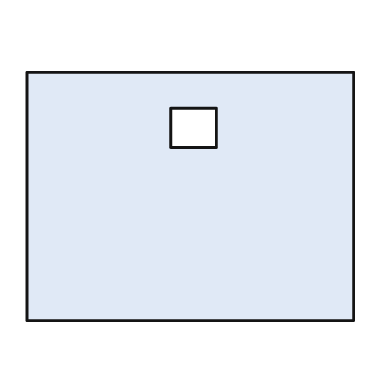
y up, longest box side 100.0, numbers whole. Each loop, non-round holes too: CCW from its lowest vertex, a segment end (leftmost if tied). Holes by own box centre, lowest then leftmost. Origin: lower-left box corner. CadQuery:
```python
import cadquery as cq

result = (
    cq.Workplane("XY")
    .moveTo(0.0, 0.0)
    .lineTo(100.0, 0.0)
    .lineTo(100.0, 76.0)
    .lineTo(0.0, 76.0)
    .close()
    .moveTo(44.0, 53.0)
    .lineTo(58.0, 53.0)
    .lineTo(58.0, 65.0)
    .lineTo(44.0, 65.0)
    .close()
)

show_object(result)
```